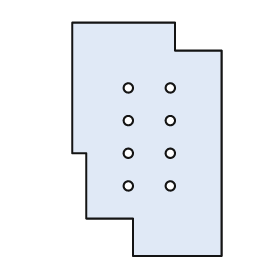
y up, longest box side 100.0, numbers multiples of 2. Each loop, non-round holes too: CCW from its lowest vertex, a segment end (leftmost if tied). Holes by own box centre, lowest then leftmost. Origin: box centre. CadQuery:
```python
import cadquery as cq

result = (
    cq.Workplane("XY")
    .moveTo(-6.0, -50.0)
    .lineTo(32.0, -50.0)
    .lineTo(32.0, 38.0)
    .lineTo(12.0, 38.0)
    .lineTo(12.0, 50.0)
    .lineTo(-32.0, 50.0)
    .lineTo(-32.0, -6.0)
    .lineTo(-26.0, -6.0)
    .lineTo(-26.0, -34.0)
    .lineTo(-6.0, -34.0)
    .close()
    .moveTo(-8.0, -20.0)
    .circle(2.0)
    .moveTo(10.0, -20.0)
    .circle(2.0)
    .moveTo(-8.0, -6.0)
    .circle(2.0)
    .moveTo(10.0, -6.0)
    .circle(2.0)
    .moveTo(-8.0, 8.0)
    .circle(2.0)
    .moveTo(10.0, 8.0)
    .circle(2.0)
    .moveTo(-8.0, 22.0)
    .circle(2.0)
    .moveTo(10.0, 22.0)
    .circle(2.0)
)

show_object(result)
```